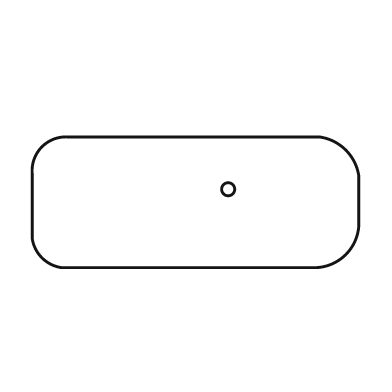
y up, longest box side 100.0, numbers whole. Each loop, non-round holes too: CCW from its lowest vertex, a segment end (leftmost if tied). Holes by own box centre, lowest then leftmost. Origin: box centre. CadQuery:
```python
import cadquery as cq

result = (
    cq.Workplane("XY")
    .moveTo(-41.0, -20.0)
    .lineTo(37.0, -20.0)
    .threePointArc((46.0, -16.0), (50.0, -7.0))
    .lineTo(50.0, 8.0)
    .threePointArc((46.0, 16.0), (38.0, 20.0))
    .lineTo(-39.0, 20.0)
    .threePointArc((-47.0, 17.0), (-50.0, 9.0))
    .lineTo(-50.0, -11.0)
    .threePointArc((-47.0, -17.0), (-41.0, -20.0))
    .close()
    .moveTo(10.0, 4.0)
    .circle(2.0)
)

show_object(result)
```